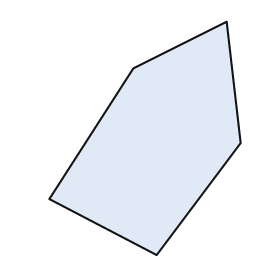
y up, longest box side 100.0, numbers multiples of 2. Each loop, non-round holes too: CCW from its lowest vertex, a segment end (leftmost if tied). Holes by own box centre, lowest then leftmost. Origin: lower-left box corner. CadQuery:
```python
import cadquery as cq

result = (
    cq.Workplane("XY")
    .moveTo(46.0, 0.0)
    .lineTo(82.0, 48.0)
    .lineTo(76.0, 100.0)
    .lineTo(36.0, 80.0)
    .lineTo(0.0, 24.0)
    .close()
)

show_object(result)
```